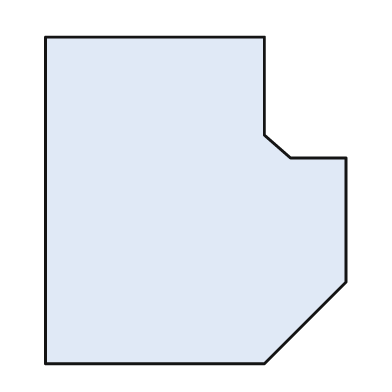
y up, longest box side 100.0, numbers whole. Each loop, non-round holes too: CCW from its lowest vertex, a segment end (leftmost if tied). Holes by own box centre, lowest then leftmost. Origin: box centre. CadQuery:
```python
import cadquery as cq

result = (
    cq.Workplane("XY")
    .moveTo(-46.0, -50.0)
    .lineTo(21.0, -50.0)
    .lineTo(46.0, -25.0)
    .lineTo(46.0, 13.0)
    .lineTo(29.0, 13.0)
    .lineTo(21.0, 20.0)
    .lineTo(21.0, 50.0)
    .lineTo(-46.0, 50.0)
    .close()
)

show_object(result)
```